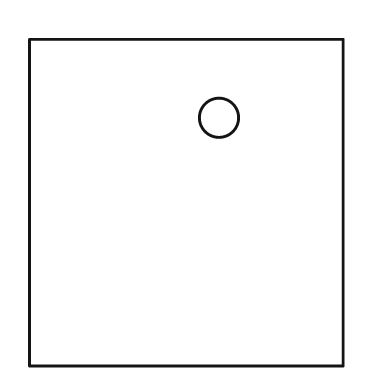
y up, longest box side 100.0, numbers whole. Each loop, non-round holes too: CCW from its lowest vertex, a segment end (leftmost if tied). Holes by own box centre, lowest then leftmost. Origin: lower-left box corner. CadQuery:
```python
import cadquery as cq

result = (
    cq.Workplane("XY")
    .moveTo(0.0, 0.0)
    .lineTo(96.0, 0.0)
    .lineTo(96.0, 100.0)
    .lineTo(0.0, 100.0)
    .close()
    .moveTo(58.0, 76.0)
    .circle(6.0)
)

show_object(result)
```